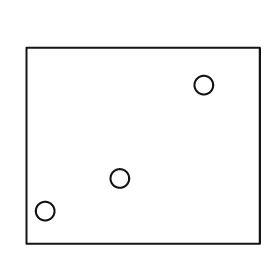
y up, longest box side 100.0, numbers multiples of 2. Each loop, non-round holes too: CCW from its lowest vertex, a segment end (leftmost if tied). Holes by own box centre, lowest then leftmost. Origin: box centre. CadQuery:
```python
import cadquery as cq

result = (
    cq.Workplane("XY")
    .moveTo(-50.0, -42.0)
    .lineTo(50.0, -42.0)
    .lineTo(50.0, 42.0)
    .lineTo(-50.0, 42.0)
    .close()
    .moveTo(-42.0, -28.0)
    .circle(4.0)
    .moveTo(-10.0, -14.0)
    .circle(4.0)
    .moveTo(26.0, 26.0)
    .circle(4.0)
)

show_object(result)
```